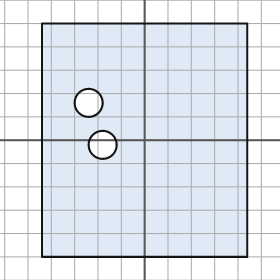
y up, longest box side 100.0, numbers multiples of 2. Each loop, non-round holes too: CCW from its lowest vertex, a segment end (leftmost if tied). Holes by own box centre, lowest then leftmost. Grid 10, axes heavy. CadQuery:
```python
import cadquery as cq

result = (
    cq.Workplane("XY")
    .moveTo(-44.0, -50.0)
    .lineTo(44.0, -50.0)
    .lineTo(44.0, 50.0)
    .lineTo(-44.0, 50.0)
    .close()
    .moveTo(-18.0, -2.0)
    .circle(6.0)
    .moveTo(-24.0, 16.0)
    .circle(6.0)
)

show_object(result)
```